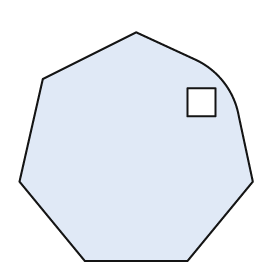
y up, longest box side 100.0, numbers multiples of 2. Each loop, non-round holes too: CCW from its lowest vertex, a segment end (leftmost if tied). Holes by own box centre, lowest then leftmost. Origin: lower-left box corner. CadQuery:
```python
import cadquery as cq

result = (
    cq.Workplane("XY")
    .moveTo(28.0, 0.0)
    .lineTo(72.0, 0.0)
    .lineTo(100.0, 34.0)
    .lineTo(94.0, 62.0)
    .threePointArc((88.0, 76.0), (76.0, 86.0))
    .lineTo(50.0, 98.0)
    .lineTo(10.0, 78.0)
    .lineTo(0.0, 34.0)
    .close()
    .moveTo(72.0, 62.0)
    .lineTo(84.0, 62.0)
    .lineTo(84.0, 74.0)
    .lineTo(72.0, 74.0)
    .close()
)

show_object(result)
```